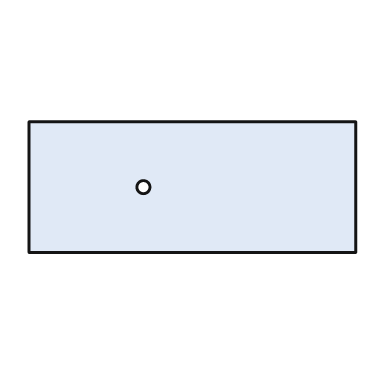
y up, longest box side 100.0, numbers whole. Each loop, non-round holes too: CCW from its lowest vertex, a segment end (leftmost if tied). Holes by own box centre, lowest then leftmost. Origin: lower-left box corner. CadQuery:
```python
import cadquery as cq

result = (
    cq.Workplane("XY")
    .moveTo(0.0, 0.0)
    .lineTo(100.0, 0.0)
    .lineTo(100.0, 40.0)
    .lineTo(0.0, 40.0)
    .close()
    .moveTo(35.0, 20.0)
    .circle(2.0)
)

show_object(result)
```